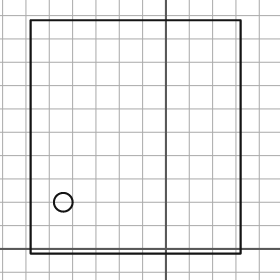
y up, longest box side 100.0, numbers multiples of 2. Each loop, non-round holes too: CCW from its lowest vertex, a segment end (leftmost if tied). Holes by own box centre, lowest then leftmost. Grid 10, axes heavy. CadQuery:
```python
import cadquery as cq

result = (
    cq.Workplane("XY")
    .moveTo(-58.0, -2.0)
    .lineTo(32.0, -2.0)
    .lineTo(32.0, 98.0)
    .lineTo(-58.0, 98.0)
    .close()
    .moveTo(-44.0, 20.0)
    .circle(4.0)
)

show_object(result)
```